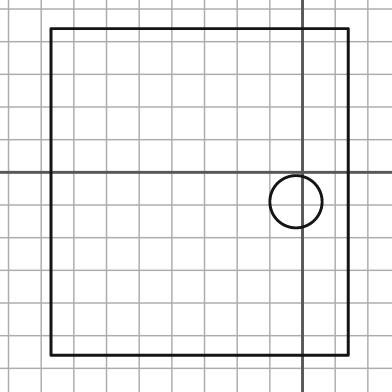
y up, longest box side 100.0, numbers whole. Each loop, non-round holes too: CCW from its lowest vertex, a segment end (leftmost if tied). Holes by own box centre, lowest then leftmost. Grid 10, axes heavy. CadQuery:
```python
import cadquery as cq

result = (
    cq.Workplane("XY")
    .moveTo(-77.0, -56.0)
    .lineTo(14.0, -56.0)
    .lineTo(14.0, 44.0)
    .lineTo(-77.0, 44.0)
    .close()
    .moveTo(-2.0, -9.0)
    .circle(8.0)
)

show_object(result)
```